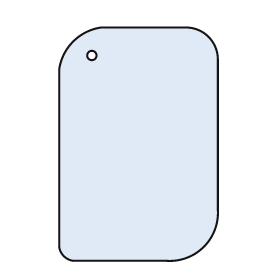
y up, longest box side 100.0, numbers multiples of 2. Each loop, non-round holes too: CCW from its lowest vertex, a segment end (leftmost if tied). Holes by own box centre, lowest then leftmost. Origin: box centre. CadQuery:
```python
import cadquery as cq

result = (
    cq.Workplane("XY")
    .moveTo(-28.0, -50.0)
    .lineTo(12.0, -50.0)
    .threePointArc((28.0, -44.0), (34.0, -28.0))
    .lineTo(34.0, 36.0)
    .threePointArc((30.0, 46.0), (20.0, 50.0))
    .lineTo(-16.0, 50.0)
    .threePointArc((-28.0, 44.0), (-34.0, 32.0))
    .lineTo(-34.0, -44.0)
    .threePointArc((-32.0, -48.0), (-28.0, -50.0))
    .close()
    .moveTo(-20.0, 38.0)
    .circle(2.0)
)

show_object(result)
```